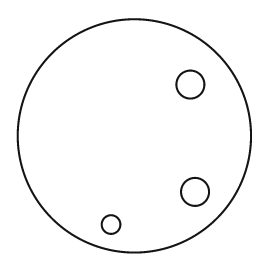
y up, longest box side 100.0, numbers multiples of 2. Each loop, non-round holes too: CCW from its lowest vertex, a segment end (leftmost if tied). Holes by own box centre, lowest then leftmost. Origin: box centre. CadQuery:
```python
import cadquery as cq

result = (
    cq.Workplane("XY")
    .moveTo(0.0, 0.0)
    .circle(50.0)
    .moveTo(-10.0, -38.0)
    .circle(4.0)
    .moveTo(26.0, -24.0)
    .circle(6.0)
    .moveTo(24.0, 22.0)
    .circle(6.0)
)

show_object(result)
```